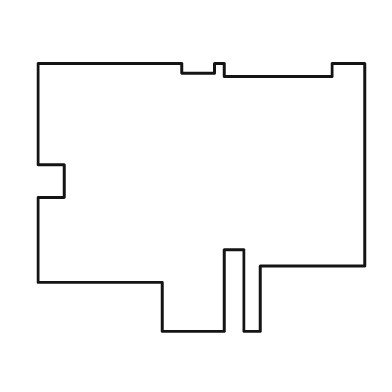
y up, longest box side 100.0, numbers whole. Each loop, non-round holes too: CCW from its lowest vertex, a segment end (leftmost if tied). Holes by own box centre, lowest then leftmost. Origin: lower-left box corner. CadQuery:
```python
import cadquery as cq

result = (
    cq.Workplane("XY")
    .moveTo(38.0, 0.0)
    .lineTo(57.0, 0.0)
    .lineTo(57.0, 25.0)
    .lineTo(63.0, 25.0)
    .lineTo(63.0, 0.0)
    .lineTo(68.0, 0.0)
    .lineTo(68.0, 20.0)
    .lineTo(100.0, 20.0)
    .lineTo(100.0, 82.0)
    .lineTo(90.0, 82.0)
    .lineTo(90.0, 78.0)
    .lineTo(57.0, 78.0)
    .lineTo(57.0, 82.0)
    .lineTo(54.0, 82.0)
    .lineTo(54.0, 79.0)
    .lineTo(44.0, 79.0)
    .lineTo(44.0, 82.0)
    .lineTo(0.0, 82.0)
    .lineTo(0.0, 51.0)
    .lineTo(8.0, 51.0)
    .lineTo(8.0, 41.0)
    .lineTo(0.0, 41.0)
    .lineTo(0.0, 15.0)
    .lineTo(38.0, 15.0)
    .close()
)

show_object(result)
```